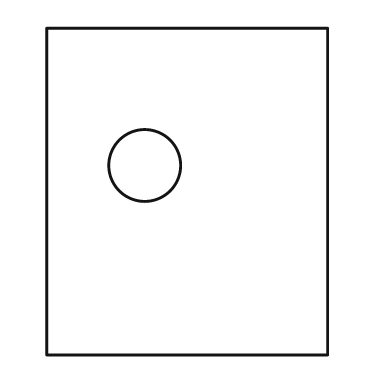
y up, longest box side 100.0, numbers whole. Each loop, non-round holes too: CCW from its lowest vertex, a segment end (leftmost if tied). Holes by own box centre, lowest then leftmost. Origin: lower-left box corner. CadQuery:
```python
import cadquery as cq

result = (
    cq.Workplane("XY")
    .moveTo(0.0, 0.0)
    .lineTo(86.0, 0.0)
    .lineTo(86.0, 100.0)
    .lineTo(0.0, 100.0)
    .close()
    .moveTo(30.0, 58.0)
    .circle(11.0)
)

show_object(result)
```